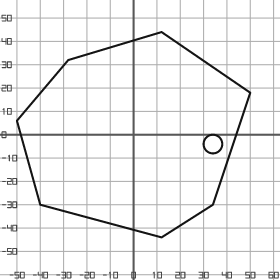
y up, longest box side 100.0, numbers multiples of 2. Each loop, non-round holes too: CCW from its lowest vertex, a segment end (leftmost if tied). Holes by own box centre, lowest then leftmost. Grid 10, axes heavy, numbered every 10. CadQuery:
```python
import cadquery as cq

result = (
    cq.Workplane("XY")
    .moveTo(12.0, -44.0)
    .lineTo(34.0, -30.0)
    .lineTo(50.0, 18.0)
    .lineTo(12.0, 44.0)
    .lineTo(-28.0, 32.0)
    .lineTo(-50.0, 6.0)
    .lineTo(-40.0, -30.0)
    .close()
    .moveTo(34.0, -4.0)
    .circle(4.0)
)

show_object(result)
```